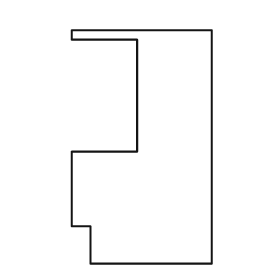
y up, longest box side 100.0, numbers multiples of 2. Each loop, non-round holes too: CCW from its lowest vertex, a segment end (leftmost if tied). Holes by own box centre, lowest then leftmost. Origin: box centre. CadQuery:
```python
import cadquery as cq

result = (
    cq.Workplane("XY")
    .moveTo(-22.0, -50.0)
    .lineTo(30.0, -50.0)
    .lineTo(30.0, 50.0)
    .lineTo(-30.0, 50.0)
    .lineTo(-30.0, 46.0)
    .lineTo(-2.0, 46.0)
    .lineTo(-2.0, -2.0)
    .lineTo(-30.0, -2.0)
    .lineTo(-30.0, -34.0)
    .lineTo(-22.0, -34.0)
    .close()
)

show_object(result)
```